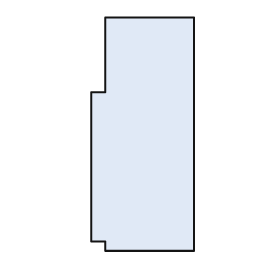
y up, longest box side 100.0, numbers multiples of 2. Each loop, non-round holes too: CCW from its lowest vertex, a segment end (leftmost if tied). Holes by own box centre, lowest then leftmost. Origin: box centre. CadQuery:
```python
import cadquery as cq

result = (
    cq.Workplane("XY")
    .moveTo(-16.0, -50.0)
    .lineTo(22.0, -50.0)
    .lineTo(22.0, 50.0)
    .lineTo(-16.0, 50.0)
    .lineTo(-16.0, 18.0)
    .lineTo(-22.0, 18.0)
    .lineTo(-22.0, -46.0)
    .lineTo(-16.0, -46.0)
    .close()
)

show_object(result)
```